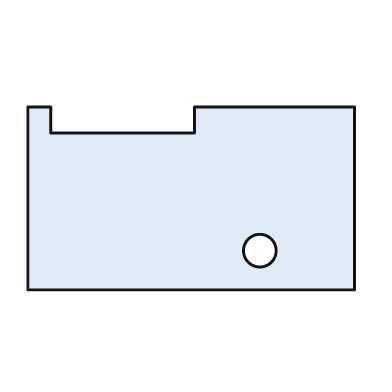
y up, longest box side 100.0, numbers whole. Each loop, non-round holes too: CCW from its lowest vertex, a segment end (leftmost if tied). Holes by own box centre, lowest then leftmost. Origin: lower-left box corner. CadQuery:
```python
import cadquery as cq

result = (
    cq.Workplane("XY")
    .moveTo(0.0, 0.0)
    .lineTo(100.0, 0.0)
    .lineTo(100.0, 56.0)
    .lineTo(51.0, 56.0)
    .lineTo(51.0, 48.0)
    .lineTo(7.0, 48.0)
    .lineTo(7.0, 56.0)
    .lineTo(0.0, 56.0)
    .close()
    .moveTo(71.0, 12.0)
    .circle(5.0)
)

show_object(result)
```